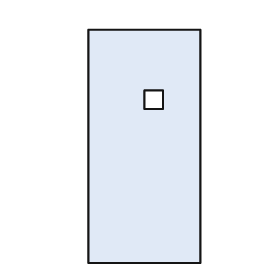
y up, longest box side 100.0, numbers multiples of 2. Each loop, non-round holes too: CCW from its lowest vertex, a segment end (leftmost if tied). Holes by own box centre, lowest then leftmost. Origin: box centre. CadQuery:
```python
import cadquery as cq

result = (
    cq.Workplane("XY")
    .moveTo(-24.0, -50.0)
    .lineTo(24.0, -50.0)
    .lineTo(24.0, 50.0)
    .lineTo(-24.0, 50.0)
    .close()
    .moveTo(0.0, 16.0)
    .lineTo(8.0, 16.0)
    .lineTo(8.0, 24.0)
    .lineTo(0.0, 24.0)
    .close()
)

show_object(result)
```